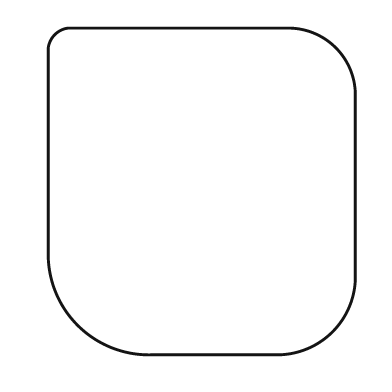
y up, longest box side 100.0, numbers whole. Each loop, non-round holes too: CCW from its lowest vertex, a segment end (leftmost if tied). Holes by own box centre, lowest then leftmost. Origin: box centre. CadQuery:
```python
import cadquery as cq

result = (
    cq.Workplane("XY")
    .moveTo(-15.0, -50.0)
    .lineTo(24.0, -50.0)
    .threePointArc((40.0, -43.0), (47.0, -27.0))
    .lineTo(47.0, 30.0)
    .threePointArc((41.0, 44.0), (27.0, 50.0))
    .lineTo(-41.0, 50.0)
    .threePointArc((-45.0, 48.0), (-47.0, 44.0))
    .lineTo(-47.0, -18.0)
    .threePointArc((-38.0, -41.0), (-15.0, -50.0))
    .close()
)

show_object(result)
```